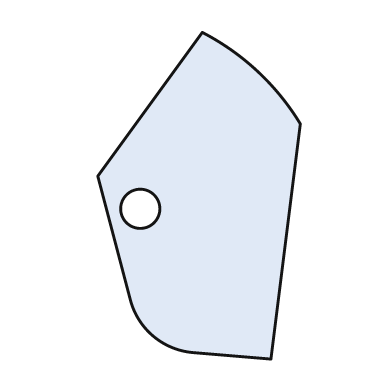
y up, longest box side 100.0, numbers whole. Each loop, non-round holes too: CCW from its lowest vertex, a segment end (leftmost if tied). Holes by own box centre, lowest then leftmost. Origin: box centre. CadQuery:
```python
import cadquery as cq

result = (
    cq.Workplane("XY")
    .moveTo(22.0, -50.0)
    .lineTo(31.0, 22.0)
    .threePointArc((18.0, 38.0), (1.0, 50.0))
    .lineTo(-31.0, 6.0)
    .lineTo(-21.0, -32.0)
    .threePointArc((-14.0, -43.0), (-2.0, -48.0))
    .close()
    .moveTo(-18.0, -4.0)
    .circle(6.0)
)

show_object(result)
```